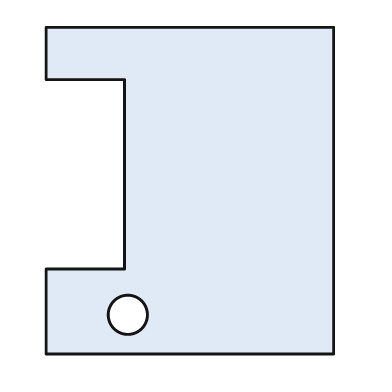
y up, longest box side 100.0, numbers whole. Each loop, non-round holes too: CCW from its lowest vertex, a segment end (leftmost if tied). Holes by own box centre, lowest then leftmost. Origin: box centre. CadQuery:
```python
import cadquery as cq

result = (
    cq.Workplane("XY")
    .moveTo(-44.0, -50.0)
    .lineTo(44.0, -50.0)
    .lineTo(44.0, 50.0)
    .lineTo(-44.0, 50.0)
    .lineTo(-44.0, 34.0)
    .lineTo(-20.0, 34.0)
    .lineTo(-20.0, -24.0)
    .lineTo(-44.0, -24.0)
    .close()
    .moveTo(-19.0, -38.0)
    .circle(6.0)
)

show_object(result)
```